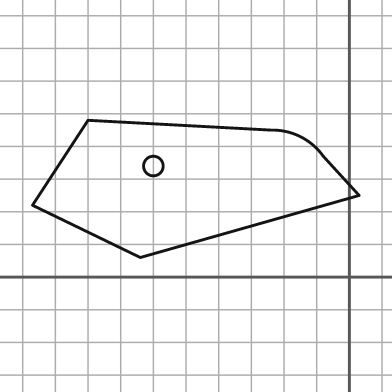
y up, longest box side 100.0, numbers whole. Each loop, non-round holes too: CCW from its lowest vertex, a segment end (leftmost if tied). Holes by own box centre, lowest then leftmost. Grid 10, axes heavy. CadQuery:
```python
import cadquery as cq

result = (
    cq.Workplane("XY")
    .moveTo(-64.0, 6.0)
    .lineTo(3.0, 25.0)
    .lineTo(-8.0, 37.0)
    .threePointArc((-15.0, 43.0), (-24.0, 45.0))
    .lineTo(-80.0, 48.0)
    .lineTo(-97.0, 22.0)
    .close()
    .moveTo(-60.0, 34.0)
    .circle(3.0)
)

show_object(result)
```